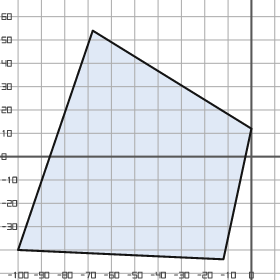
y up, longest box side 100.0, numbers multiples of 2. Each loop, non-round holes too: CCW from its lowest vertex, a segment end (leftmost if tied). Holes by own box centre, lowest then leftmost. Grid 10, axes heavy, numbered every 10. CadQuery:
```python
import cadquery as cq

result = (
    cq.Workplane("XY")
    .moveTo(-12.0, -44.0)
    .lineTo(0.0, 12.0)
    .lineTo(-68.0, 54.0)
    .lineTo(-100.0, -40.0)
    .close()
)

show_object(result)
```